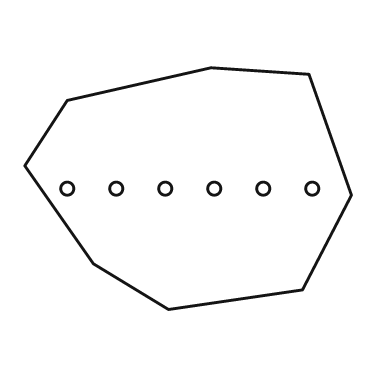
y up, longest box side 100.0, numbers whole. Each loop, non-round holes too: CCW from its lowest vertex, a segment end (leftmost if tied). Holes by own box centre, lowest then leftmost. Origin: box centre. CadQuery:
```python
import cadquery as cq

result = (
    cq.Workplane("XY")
    .moveTo(-6.0, -37.0)
    .lineTo(35.0, -31.0)
    .lineTo(50.0, -2.0)
    .lineTo(37.0, 35.0)
    .lineTo(7.0, 37.0)
    .lineTo(-37.0, 27.0)
    .lineTo(-50.0, 7.0)
    .lineTo(-29.0, -23.0)
    .close()
    .moveTo(-37.0, 0.0)
    .circle(2.0)
    .moveTo(-22.0, 0.0)
    .circle(2.0)
    .moveTo(-7.0, 0.0)
    .circle(2.0)
    .moveTo(8.0, 0.0)
    .circle(2.0)
    .moveTo(23.0, 0.0)
    .circle(2.0)
    .moveTo(38.0, 0.0)
    .circle(2.0)
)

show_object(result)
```